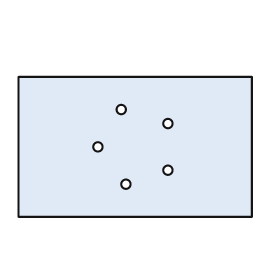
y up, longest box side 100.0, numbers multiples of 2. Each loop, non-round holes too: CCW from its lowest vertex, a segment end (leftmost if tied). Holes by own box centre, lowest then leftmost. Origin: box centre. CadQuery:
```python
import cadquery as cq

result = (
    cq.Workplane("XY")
    .moveTo(-50.0, -30.0)
    .lineTo(50.0, -30.0)
    .lineTo(50.0, 30.0)
    .lineTo(-50.0, 30.0)
    .close()
    .moveTo(-4.0, -16.0)
    .circle(2.0)
    .moveTo(14.0, -10.0)
    .circle(2.0)
    .moveTo(-16.0, 0.0)
    .circle(2.0)
    .moveTo(14.0, 10.0)
    .circle(2.0)
    .moveTo(-6.0, 16.0)
    .circle(2.0)
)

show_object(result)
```